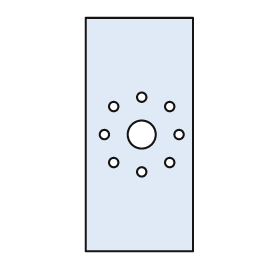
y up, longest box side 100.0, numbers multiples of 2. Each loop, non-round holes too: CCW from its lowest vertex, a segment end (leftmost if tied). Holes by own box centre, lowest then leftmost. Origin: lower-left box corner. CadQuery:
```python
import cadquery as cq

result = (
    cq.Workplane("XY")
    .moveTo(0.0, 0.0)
    .lineTo(46.0, 0.0)
    .lineTo(46.0, 100.0)
    .lineTo(0.0, 100.0)
    .close()
    .moveTo(24.0, 34.0)
    .circle(2.0)
    .moveTo(12.0, 38.0)
    .circle(2.0)
    .moveTo(36.0, 38.0)
    .circle(2.0)
    .moveTo(8.0, 50.0)
    .circle(2.0)
    .moveTo(24.0, 50.0)
    .circle(6.0)
    .moveTo(40.0, 50.0)
    .circle(2.0)
    .moveTo(12.0, 62.0)
    .circle(2.0)
    .moveTo(36.0, 62.0)
    .circle(2.0)
    .moveTo(24.0, 66.0)
    .circle(2.0)
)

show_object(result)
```